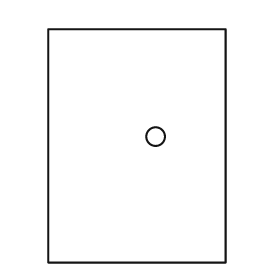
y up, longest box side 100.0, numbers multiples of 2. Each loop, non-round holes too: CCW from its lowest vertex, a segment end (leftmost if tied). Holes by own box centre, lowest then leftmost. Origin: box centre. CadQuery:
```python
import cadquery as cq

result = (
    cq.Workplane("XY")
    .moveTo(-38.0, -50.0)
    .lineTo(38.0, -50.0)
    .lineTo(38.0, 50.0)
    .lineTo(-38.0, 50.0)
    .close()
    .moveTo(8.0, 4.0)
    .circle(4.0)
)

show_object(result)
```